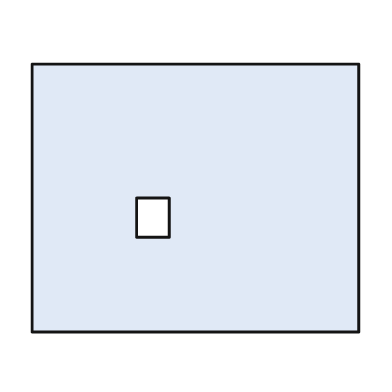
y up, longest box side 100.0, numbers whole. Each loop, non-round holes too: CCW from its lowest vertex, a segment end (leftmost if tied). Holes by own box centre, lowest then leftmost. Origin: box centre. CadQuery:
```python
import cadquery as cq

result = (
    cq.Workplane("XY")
    .moveTo(-50.0, -41.0)
    .lineTo(50.0, -41.0)
    .lineTo(50.0, 41.0)
    .lineTo(-50.0, 41.0)
    .close()
    .moveTo(-18.0, -12.0)
    .lineTo(-8.0, -12.0)
    .lineTo(-8.0, 0.0)
    .lineTo(-18.0, 0.0)
    .close()
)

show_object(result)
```